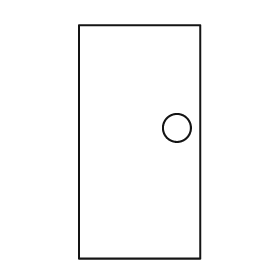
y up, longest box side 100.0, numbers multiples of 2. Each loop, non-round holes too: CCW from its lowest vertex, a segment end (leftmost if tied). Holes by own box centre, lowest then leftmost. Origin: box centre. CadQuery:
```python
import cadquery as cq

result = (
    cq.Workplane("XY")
    .moveTo(-26.0, -50.0)
    .lineTo(26.0, -50.0)
    .lineTo(26.0, 50.0)
    .lineTo(-26.0, 50.0)
    .close()
    .moveTo(16.0, 6.0)
    .circle(6.0)
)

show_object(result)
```